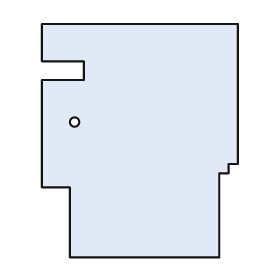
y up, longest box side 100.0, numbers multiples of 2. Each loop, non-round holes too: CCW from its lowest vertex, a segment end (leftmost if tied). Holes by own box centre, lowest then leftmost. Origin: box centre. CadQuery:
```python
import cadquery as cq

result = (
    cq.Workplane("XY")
    .moveTo(-30.0, -50.0)
    .lineTo(34.0, -50.0)
    .lineTo(34.0, -14.0)
    .lineTo(38.0, -14.0)
    .lineTo(38.0, -10.0)
    .lineTo(42.0, -10.0)
    .lineTo(42.0, 50.0)
    .lineTo(-42.0, 50.0)
    .lineTo(-42.0, 34.0)
    .lineTo(-24.0, 34.0)
    .lineTo(-24.0, 26.0)
    .lineTo(-42.0, 26.0)
    .lineTo(-42.0, -20.0)
    .lineTo(-30.0, -20.0)
    .close()
    .moveTo(-28.0, 8.0)
    .circle(2.0)
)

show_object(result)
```